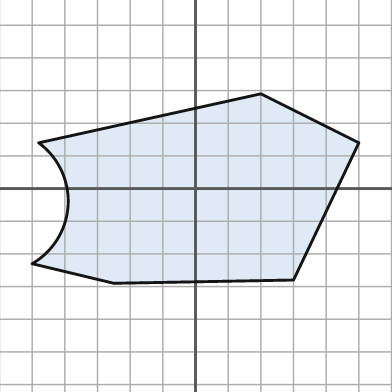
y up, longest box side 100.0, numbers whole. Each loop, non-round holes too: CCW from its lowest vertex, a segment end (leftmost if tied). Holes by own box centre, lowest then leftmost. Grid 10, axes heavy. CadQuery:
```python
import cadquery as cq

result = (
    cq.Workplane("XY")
    .moveTo(-25.0, -29.0)
    .lineTo(30.0, -28.0)
    .lineTo(50.0, 14.0)
    .lineTo(20.0, 29.0)
    .lineTo(-48.0, 14.0)
    .threePointArc((-39.0, -5.0), (-50.0, -23.0))
    .close()
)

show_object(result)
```